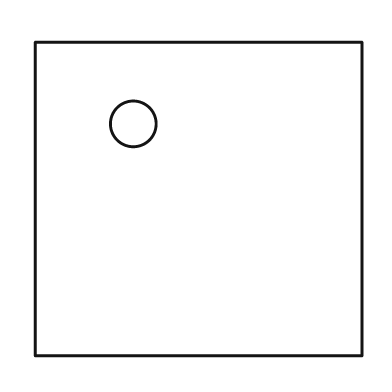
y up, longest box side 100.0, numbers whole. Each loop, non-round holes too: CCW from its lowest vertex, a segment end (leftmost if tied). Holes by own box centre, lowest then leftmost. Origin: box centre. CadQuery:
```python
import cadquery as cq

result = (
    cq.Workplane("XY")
    .moveTo(-50.0, -48.0)
    .lineTo(50.0, -48.0)
    .lineTo(50.0, 48.0)
    .lineTo(-50.0, 48.0)
    .close()
    .moveTo(-20.0, 23.0)
    .circle(7.0)
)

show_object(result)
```